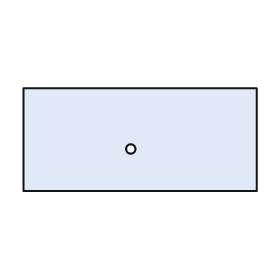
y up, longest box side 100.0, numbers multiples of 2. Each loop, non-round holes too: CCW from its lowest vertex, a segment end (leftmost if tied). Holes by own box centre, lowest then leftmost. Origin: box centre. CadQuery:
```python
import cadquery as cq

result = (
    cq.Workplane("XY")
    .moveTo(-50.0, -22.0)
    .lineTo(50.0, -22.0)
    .lineTo(50.0, 22.0)
    .lineTo(-50.0, 22.0)
    .close()
    .moveTo(-4.0, -4.0)
    .circle(2.0)
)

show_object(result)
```